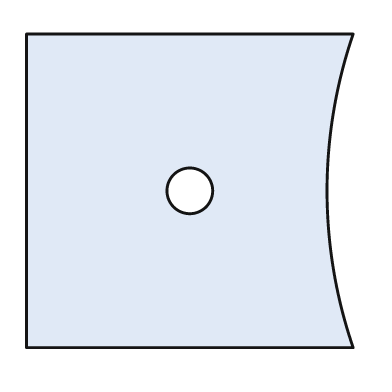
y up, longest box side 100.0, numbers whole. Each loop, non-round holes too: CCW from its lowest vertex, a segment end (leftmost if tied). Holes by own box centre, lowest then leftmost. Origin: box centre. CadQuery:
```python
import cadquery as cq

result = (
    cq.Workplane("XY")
    .moveTo(-50.0, -48.0)
    .lineTo(50.0, -48.0)
    .threePointArc((42.0, 0.0), (50.0, 48.0))
    .lineTo(-50.0, 48.0)
    .close()
    .moveTo(0.0, 0.0)
    .circle(7.0)
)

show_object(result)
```